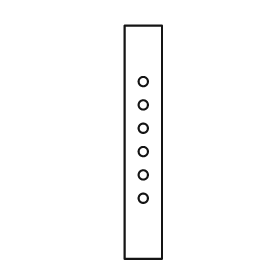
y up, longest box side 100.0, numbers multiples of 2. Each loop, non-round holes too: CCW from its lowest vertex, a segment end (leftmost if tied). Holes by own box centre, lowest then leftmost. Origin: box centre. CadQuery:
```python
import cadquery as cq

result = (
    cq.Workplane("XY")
    .moveTo(-8.0, -50.0)
    .lineTo(8.0, -50.0)
    .lineTo(8.0, 50.0)
    .lineTo(-8.0, 50.0)
    .close()
    .moveTo(0.0, -24.0)
    .circle(2.0)
    .moveTo(0.0, -14.0)
    .circle(2.0)
    .moveTo(0.0, -4.0)
    .circle(2.0)
    .moveTo(0.0, 6.0)
    .circle(2.0)
    .moveTo(0.0, 16.0)
    .circle(2.0)
    .moveTo(0.0, 26.0)
    .circle(2.0)
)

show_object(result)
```